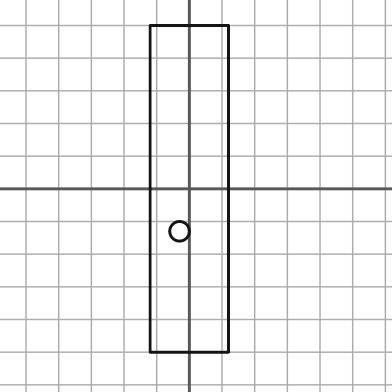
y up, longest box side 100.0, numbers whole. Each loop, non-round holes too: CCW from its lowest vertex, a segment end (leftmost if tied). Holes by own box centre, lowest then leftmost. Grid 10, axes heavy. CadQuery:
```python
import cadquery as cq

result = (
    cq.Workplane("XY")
    .moveTo(-12.0, -50.0)
    .lineTo(12.0, -50.0)
    .lineTo(12.0, 50.0)
    .lineTo(-12.0, 50.0)
    .close()
    .moveTo(-3.0, -13.0)
    .circle(3.0)
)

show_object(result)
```